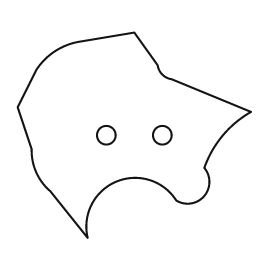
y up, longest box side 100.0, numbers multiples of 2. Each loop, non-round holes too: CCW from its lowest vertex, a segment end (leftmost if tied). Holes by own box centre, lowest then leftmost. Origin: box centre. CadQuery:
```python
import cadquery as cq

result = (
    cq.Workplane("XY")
    .moveTo(-20.0, -44.0)
    .threePointArc((-8.0, -20.0), (18.0, -28.0))
    .threePointArc((30.0, -26.0), (30.0, -14.0))
    .threePointArc((38.0, 0.0), (50.0, 10.0))
    .lineTo(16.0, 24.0)
    .threePointArc((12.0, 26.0), (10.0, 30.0))
    .lineTo(0.0, 44.0)
    .lineTo(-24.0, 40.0)
    .threePointArc((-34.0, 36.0), (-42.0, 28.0))
    .lineTo(-50.0, 12.0)
    .lineTo(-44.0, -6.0)
    .threePointArc((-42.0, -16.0), (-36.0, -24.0))
    .close()
    .moveTo(-12.0, 0.0)
    .circle(4.0)
    .moveTo(12.0, 0.0)
    .circle(4.0)
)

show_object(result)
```